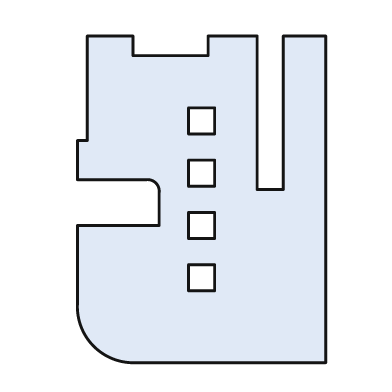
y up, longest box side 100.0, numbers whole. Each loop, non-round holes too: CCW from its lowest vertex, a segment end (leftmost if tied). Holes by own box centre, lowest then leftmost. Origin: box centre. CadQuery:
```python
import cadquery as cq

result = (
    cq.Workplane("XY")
    .moveTo(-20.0, -50.0)
    .lineTo(38.0, -50.0)
    .lineTo(38.0, 50.0)
    .lineTo(25.0, 50.0)
    .lineTo(25.0, 3.0)
    .lineTo(17.0, 3.0)
    .lineTo(17.0, 50.0)
    .lineTo(2.0, 50.0)
    .lineTo(2.0, 44.0)
    .lineTo(-21.0, 44.0)
    .lineTo(-21.0, 50.0)
    .lineTo(-35.0, 50.0)
    .lineTo(-35.0, 18.0)
    .lineTo(-38.0, 18.0)
    .lineTo(-38.0, 6.0)
    .lineTo(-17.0, 6.0)
    .threePointArc((-14.0, 5.0), (-13.0, 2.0))
    .lineTo(-13.0, -8.0)
    .lineTo(-38.0, -8.0)
    .lineTo(-38.0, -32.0)
    .threePointArc((-33.0, -45.0), (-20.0, -50.0))
    .close()
    .moveTo(-4.0, -28.0)
    .lineTo(4.0, -28.0)
    .lineTo(4.0, -20.0)
    .lineTo(-4.0, -20.0)
    .close()
    .moveTo(-4.0, -12.0)
    .lineTo(4.0, -12.0)
    .lineTo(4.0, -4.0)
    .lineTo(-4.0, -4.0)
    .close()
    .moveTo(-4.0, 4.0)
    .lineTo(4.0, 4.0)
    .lineTo(4.0, 12.0)
    .lineTo(-4.0, 12.0)
    .close()
    .moveTo(-4.0, 20.0)
    .lineTo(4.0, 20.0)
    .lineTo(4.0, 28.0)
    .lineTo(-4.0, 28.0)
    .close()
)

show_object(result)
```